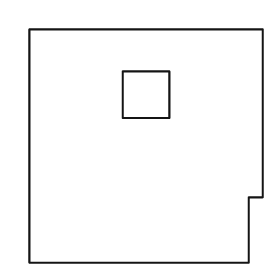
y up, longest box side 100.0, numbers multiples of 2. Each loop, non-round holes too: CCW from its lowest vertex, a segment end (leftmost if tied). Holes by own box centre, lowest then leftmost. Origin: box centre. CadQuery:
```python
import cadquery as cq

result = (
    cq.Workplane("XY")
    .moveTo(-50.0, -50.0)
    .lineTo(44.0, -50.0)
    .lineTo(44.0, -22.0)
    .lineTo(50.0, -22.0)
    .lineTo(50.0, 50.0)
    .lineTo(-50.0, 50.0)
    .close()
    .moveTo(-10.0, 12.0)
    .lineTo(10.0, 12.0)
    .lineTo(10.0, 32.0)
    .lineTo(-10.0, 32.0)
    .close()
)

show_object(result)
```